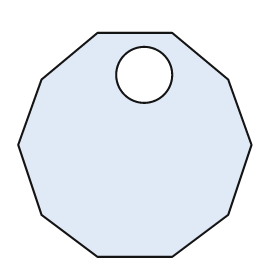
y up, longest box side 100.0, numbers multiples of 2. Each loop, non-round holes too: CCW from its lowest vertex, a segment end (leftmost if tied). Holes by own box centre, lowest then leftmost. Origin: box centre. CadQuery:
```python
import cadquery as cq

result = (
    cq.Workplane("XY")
    .moveTo(-16.0, -48.0)
    .lineTo(16.0, -48.0)
    .lineTo(40.0, -30.0)
    .lineTo(50.0, 0.0)
    .lineTo(40.0, 28.0)
    .lineTo(16.0, 48.0)
    .lineTo(-16.0, 48.0)
    .lineTo(-40.0, 28.0)
    .lineTo(-50.0, 0.0)
    .lineTo(-40.0, -30.0)
    .close()
    .moveTo(4.0, 30.0)
    .circle(12.0)
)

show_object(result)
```